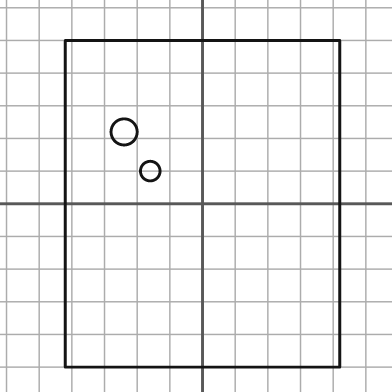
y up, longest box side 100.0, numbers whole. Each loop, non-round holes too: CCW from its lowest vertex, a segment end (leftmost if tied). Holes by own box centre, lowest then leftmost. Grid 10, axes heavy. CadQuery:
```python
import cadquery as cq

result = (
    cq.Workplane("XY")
    .moveTo(-42.0, -50.0)
    .lineTo(42.0, -50.0)
    .lineTo(42.0, 50.0)
    .lineTo(-42.0, 50.0)
    .close()
    .moveTo(-16.0, 10.0)
    .circle(3.0)
    .moveTo(-24.0, 22.0)
    .circle(4.0)
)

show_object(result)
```